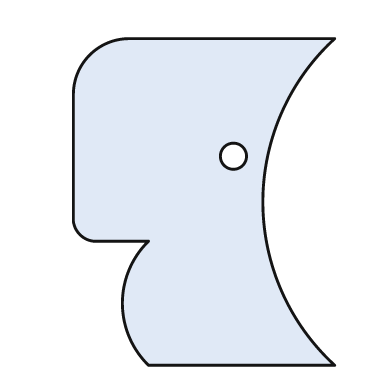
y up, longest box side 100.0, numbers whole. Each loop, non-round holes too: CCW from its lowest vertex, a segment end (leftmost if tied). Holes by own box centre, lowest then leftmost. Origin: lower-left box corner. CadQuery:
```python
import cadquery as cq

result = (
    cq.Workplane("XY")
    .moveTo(23.0, 0.0)
    .lineTo(80.0, 0.0)
    .threePointArc((58.0, 50.0), (80.0, 100.0))
    .lineTo(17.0, 100.0)
    .threePointArc((5.0, 95.0), (0.0, 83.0))
    .lineTo(0.0, 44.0)
    .threePointArc((2.0, 40.0), (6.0, 38.0))
    .lineTo(23.0, 38.0)
    .threePointArc((15.0, 19.0), (23.0, 0.0))
    .close()
    .moveTo(49.0, 64.0)
    .circle(4.0)
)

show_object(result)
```